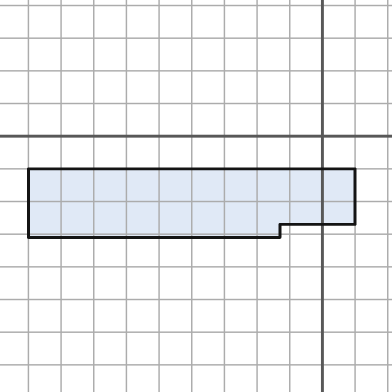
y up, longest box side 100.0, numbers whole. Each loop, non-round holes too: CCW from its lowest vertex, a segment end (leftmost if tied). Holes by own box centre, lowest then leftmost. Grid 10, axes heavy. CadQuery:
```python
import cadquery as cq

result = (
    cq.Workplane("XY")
    .moveTo(-90.0, -31.0)
    .lineTo(-13.0, -31.0)
    .lineTo(-13.0, -27.0)
    .lineTo(10.0, -27.0)
    .lineTo(10.0, -10.0)
    .lineTo(-90.0, -10.0)
    .close()
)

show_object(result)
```